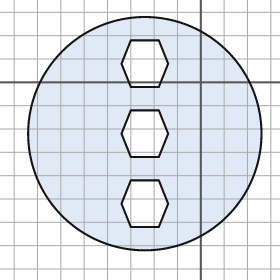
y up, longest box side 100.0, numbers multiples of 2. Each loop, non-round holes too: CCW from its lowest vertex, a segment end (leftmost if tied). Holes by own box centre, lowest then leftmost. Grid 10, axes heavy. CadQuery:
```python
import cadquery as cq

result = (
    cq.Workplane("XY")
    .moveTo(-24.0, -22.0)
    .circle(50.0)
    .moveTo(-30.0, -62.0)
    .lineTo(-18.0, -62.0)
    .lineTo(-14.0, -52.0)
    .lineTo(-18.0, -42.0)
    .lineTo(-30.0, -42.0)
    .lineTo(-34.0, -52.0)
    .close()
    .moveTo(-30.0, -32.0)
    .lineTo(-18.0, -32.0)
    .lineTo(-14.0, -22.0)
    .lineTo(-18.0, -12.0)
    .lineTo(-30.0, -12.0)
    .lineTo(-34.0, -22.0)
    .close()
    .moveTo(-30.0, -2.0)
    .lineTo(-18.0, -2.0)
    .lineTo(-14.0, 8.0)
    .lineTo(-18.0, 18.0)
    .lineTo(-30.0, 18.0)
    .lineTo(-34.0, 8.0)
    .close()
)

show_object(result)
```